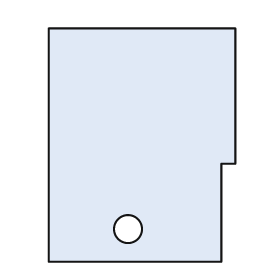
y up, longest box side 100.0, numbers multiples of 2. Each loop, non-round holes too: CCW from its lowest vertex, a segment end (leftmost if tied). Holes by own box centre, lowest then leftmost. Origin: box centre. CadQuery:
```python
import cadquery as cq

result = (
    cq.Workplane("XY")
    .moveTo(-40.0, -50.0)
    .lineTo(34.0, -50.0)
    .lineTo(34.0, -8.0)
    .lineTo(40.0, -8.0)
    .lineTo(40.0, 50.0)
    .lineTo(-40.0, 50.0)
    .close()
    .moveTo(-6.0, -36.0)
    .circle(6.0)
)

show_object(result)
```